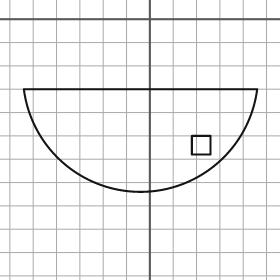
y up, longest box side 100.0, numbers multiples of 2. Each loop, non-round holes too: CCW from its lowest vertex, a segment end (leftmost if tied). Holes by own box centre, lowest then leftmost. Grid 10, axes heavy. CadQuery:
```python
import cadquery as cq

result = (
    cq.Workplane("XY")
    .moveTo(-54.0, -30.0)
    .threePointArc((-4.0, -74.0), (46.0, -30.0))
    .close()
    .moveTo(18.0, -58.0)
    .lineTo(26.0, -58.0)
    .lineTo(26.0, -50.0)
    .lineTo(18.0, -50.0)
    .close()
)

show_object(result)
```